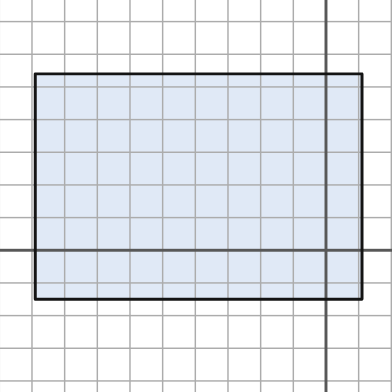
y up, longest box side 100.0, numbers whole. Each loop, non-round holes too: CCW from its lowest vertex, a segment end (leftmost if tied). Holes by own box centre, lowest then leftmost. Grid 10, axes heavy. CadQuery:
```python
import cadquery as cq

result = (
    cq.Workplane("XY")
    .moveTo(-89.0, -15.0)
    .lineTo(11.0, -15.0)
    .lineTo(11.0, 54.0)
    .lineTo(-89.0, 54.0)
    .close()
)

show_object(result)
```